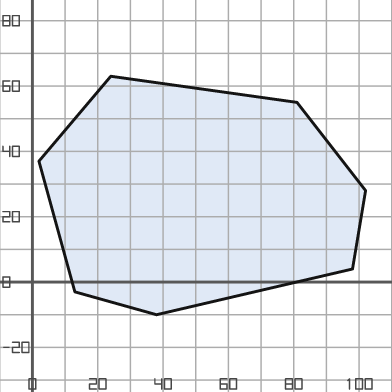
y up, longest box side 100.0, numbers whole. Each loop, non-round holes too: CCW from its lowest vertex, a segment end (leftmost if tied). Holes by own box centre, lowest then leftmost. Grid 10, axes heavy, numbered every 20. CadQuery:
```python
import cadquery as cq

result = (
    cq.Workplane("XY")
    .moveTo(38.0, -10.0)
    .lineTo(98.0, 4.0)
    .lineTo(102.0, 28.0)
    .lineTo(81.0, 55.0)
    .lineTo(24.0, 63.0)
    .lineTo(2.0, 37.0)
    .lineTo(13.0, -3.0)
    .close()
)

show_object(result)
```